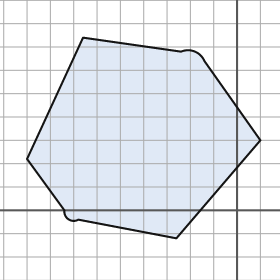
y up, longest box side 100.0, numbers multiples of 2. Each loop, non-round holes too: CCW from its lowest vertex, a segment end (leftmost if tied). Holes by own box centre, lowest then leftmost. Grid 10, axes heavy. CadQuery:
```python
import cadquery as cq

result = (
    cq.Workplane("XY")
    .moveTo(-26.0, -12.0)
    .lineTo(10.0, 30.0)
    .lineTo(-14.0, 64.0)
    .threePointArc((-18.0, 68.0), (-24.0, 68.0))
    .lineTo(-66.0, 74.0)
    .lineTo(-90.0, 22.0)
    .lineTo(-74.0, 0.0)
    .threePointArc((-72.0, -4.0), (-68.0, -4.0))
    .close()
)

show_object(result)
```